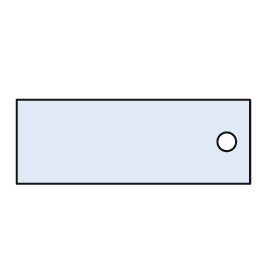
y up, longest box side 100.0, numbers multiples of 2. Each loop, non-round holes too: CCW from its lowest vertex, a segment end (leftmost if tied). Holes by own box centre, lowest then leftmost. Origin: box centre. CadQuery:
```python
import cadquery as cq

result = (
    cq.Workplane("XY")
    .moveTo(-50.0, -18.0)
    .lineTo(50.0, -18.0)
    .lineTo(50.0, 18.0)
    .lineTo(-50.0, 18.0)
    .close()
    .moveTo(40.0, 0.0)
    .circle(4.0)
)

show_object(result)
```